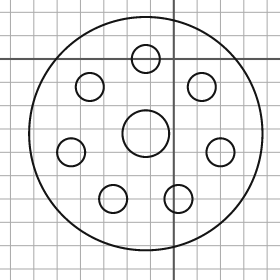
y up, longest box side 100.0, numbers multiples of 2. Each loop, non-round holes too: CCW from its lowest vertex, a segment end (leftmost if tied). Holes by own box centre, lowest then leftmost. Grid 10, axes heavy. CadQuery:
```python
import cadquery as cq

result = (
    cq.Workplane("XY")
    .moveTo(-12.0, -32.0)
    .circle(50.0)
    .moveTo(-26.0, -60.0)
    .circle(6.0)
    .moveTo(2.0, -60.0)
    .circle(6.0)
    .moveTo(-44.0, -40.0)
    .circle(6.0)
    .moveTo(20.0, -40.0)
    .circle(6.0)
    .moveTo(-12.0, -32.0)
    .circle(10.0)
    .moveTo(-36.0, -12.0)
    .circle(6.0)
    .moveTo(12.0, -12.0)
    .circle(6.0)
    .moveTo(-12.0, 0.0)
    .circle(6.0)
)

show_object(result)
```